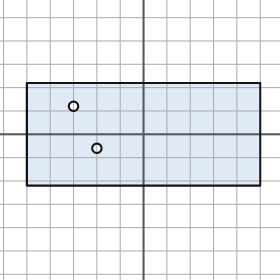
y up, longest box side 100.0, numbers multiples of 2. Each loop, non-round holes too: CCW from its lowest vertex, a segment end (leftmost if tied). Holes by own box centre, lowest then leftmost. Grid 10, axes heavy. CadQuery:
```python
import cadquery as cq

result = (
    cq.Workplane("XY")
    .moveTo(-50.0, -22.0)
    .lineTo(50.0, -22.0)
    .lineTo(50.0, 22.0)
    .lineTo(-50.0, 22.0)
    .close()
    .moveTo(-20.0, -6.0)
    .circle(2.0)
    .moveTo(-30.0, 12.0)
    .circle(2.0)
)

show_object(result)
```